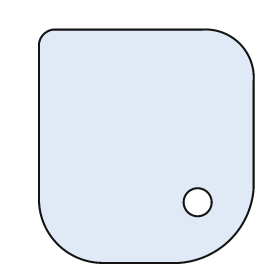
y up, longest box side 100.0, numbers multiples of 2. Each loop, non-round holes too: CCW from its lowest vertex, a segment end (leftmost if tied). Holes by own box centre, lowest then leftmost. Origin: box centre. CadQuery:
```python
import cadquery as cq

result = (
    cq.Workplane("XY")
    .moveTo(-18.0, -50.0)
    .lineTo(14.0, -50.0)
    .threePointArc((36.0, -40.0), (46.0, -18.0))
    .lineTo(46.0, 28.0)
    .threePointArc((40.0, 44.0), (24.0, 50.0))
    .lineTo(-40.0, 50.0)
    .threePointArc((-44.0, 48.0), (-46.0, 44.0))
    .lineTo(-46.0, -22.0)
    .threePointArc((-38.0, -42.0), (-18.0, -50.0))
    .close()
    .moveTo(22.0, -24.0)
    .circle(6.0)
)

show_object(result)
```